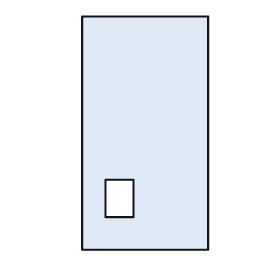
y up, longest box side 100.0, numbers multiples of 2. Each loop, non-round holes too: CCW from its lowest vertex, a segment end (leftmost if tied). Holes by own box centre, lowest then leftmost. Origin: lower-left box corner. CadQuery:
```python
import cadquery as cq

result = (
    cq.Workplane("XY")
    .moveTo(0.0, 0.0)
    .lineTo(54.0, 0.0)
    .lineTo(54.0, 100.0)
    .lineTo(0.0, 100.0)
    .close()
    .moveTo(10.0, 14.0)
    .lineTo(22.0, 14.0)
    .lineTo(22.0, 30.0)
    .lineTo(10.0, 30.0)
    .close()
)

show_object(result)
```